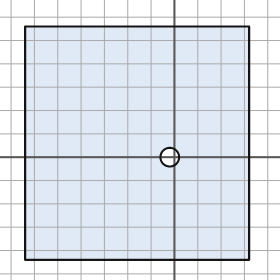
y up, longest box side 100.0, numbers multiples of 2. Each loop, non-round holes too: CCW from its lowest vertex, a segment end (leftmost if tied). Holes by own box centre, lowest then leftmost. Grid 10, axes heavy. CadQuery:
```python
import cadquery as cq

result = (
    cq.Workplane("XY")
    .moveTo(-64.0, -44.0)
    .lineTo(32.0, -44.0)
    .lineTo(32.0, 56.0)
    .lineTo(-64.0, 56.0)
    .close()
    .moveTo(-2.0, 0.0)
    .circle(4.0)
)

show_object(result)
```